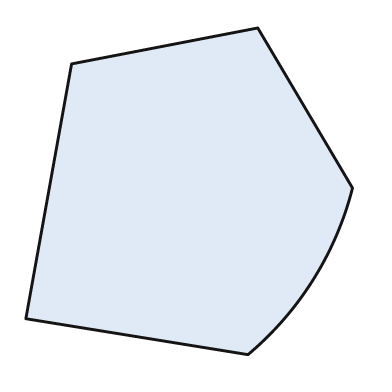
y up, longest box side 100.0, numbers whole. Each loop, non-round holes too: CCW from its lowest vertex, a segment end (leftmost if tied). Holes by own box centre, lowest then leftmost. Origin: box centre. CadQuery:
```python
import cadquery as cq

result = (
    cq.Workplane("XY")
    .moveTo(18.0, -50.0)
    .threePointArc((38.0, -27.0), (50.0, 1.0))
    .lineTo(21.0, 50.0)
    .lineTo(-36.0, 39.0)
    .lineTo(-50.0, -39.0)
    .close()
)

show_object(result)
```